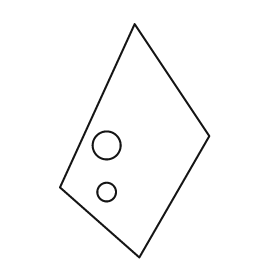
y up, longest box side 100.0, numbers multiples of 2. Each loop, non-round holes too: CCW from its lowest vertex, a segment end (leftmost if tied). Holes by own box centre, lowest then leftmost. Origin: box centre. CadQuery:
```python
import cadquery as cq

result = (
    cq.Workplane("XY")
    .moveTo(2.0, -50.0)
    .lineTo(32.0, 2.0)
    .lineTo(0.0, 50.0)
    .lineTo(-32.0, -20.0)
    .close()
    .moveTo(-12.0, -22.0)
    .circle(4.0)
    .moveTo(-12.0, -2.0)
    .circle(6.0)
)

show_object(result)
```